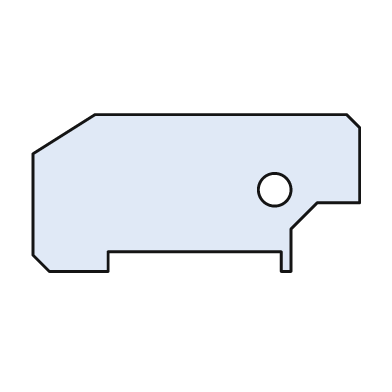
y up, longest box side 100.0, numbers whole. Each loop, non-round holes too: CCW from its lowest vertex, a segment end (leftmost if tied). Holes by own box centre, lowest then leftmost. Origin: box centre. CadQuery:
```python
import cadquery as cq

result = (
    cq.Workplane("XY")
    .moveTo(-45.0, -24.0)
    .lineTo(-27.0, -24.0)
    .lineTo(-27.0, -18.0)
    .lineTo(26.0, -18.0)
    .lineTo(26.0, -24.0)
    .lineTo(29.0, -24.0)
    .lineTo(29.0, -11.0)
    .lineTo(37.0, -3.0)
    .lineTo(50.0, -3.0)
    .lineTo(50.0, 20.0)
    .lineTo(46.0, 24.0)
    .lineTo(-31.0, 24.0)
    .lineTo(-50.0, 12.0)
    .lineTo(-50.0, -19.0)
    .close()
    .moveTo(24.0, 1.0)
    .circle(5.0)
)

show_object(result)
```